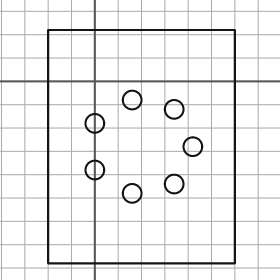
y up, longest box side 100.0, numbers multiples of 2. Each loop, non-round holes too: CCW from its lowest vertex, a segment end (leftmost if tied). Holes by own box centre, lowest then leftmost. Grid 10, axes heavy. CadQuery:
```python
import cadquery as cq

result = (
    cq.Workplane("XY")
    .moveTo(-20.0, -78.0)
    .lineTo(60.0, -78.0)
    .lineTo(60.0, 22.0)
    .lineTo(-20.0, 22.0)
    .close()
    .moveTo(16.0, -48.0)
    .circle(4.0)
    .moveTo(34.0, -44.0)
    .circle(4.0)
    .moveTo(0.0, -38.0)
    .circle(4.0)
    .moveTo(42.0, -28.0)
    .circle(4.0)
    .moveTo(0.0, -18.0)
    .circle(4.0)
    .moveTo(34.0, -12.0)
    .circle(4.0)
    .moveTo(16.0, -8.0)
    .circle(4.0)
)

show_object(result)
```